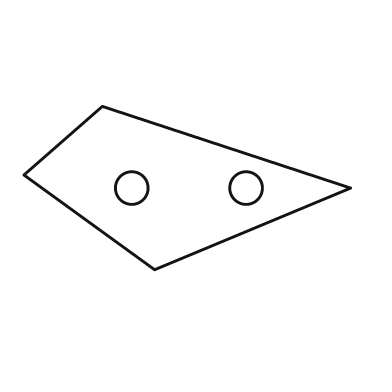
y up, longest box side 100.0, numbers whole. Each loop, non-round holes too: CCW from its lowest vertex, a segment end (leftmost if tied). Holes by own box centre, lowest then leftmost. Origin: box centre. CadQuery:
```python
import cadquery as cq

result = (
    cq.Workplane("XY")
    .moveTo(-10.0, -25.0)
    .lineTo(50.0, 0.0)
    .lineTo(-26.0, 25.0)
    .lineTo(-50.0, 4.0)
    .close()
    .moveTo(-17.0, 0.0)
    .circle(5.0)
    .moveTo(18.0, 0.0)
    .circle(5.0)
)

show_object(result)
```